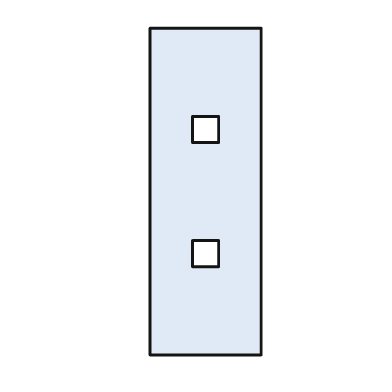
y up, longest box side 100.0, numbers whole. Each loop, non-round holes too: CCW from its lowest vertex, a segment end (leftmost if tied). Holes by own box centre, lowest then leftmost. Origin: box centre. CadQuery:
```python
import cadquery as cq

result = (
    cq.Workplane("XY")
    .moveTo(-17.0, -50.0)
    .lineTo(17.0, -50.0)
    .lineTo(17.0, 50.0)
    .lineTo(-17.0, 50.0)
    .close()
    .moveTo(-4.0, -23.0)
    .lineTo(4.0, -23.0)
    .lineTo(4.0, -15.0)
    .lineTo(-4.0, -15.0)
    .close()
    .moveTo(-4.0, 15.0)
    .lineTo(4.0, 15.0)
    .lineTo(4.0, 23.0)
    .lineTo(-4.0, 23.0)
    .close()
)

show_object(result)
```